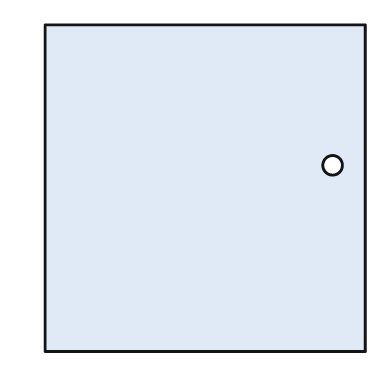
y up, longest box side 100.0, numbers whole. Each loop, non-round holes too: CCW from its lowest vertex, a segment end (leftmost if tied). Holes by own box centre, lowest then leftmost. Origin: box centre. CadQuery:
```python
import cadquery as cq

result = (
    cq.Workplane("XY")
    .moveTo(-49.0, -50.0)
    .lineTo(49.0, -50.0)
    .lineTo(49.0, 50.0)
    .lineTo(-49.0, 50.0)
    .close()
    .moveTo(39.0, 7.0)
    .circle(3.0)
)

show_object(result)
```